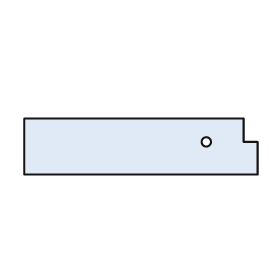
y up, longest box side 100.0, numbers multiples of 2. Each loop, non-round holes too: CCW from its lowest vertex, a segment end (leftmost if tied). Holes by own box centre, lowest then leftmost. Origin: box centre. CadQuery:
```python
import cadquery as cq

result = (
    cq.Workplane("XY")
    .moveTo(-50.0, -12.0)
    .lineTo(50.0, -12.0)
    .lineTo(50.0, 2.0)
    .lineTo(44.0, 2.0)
    .lineTo(44.0, 12.0)
    .lineTo(-50.0, 12.0)
    .close()
    .moveTo(28.0, 2.0)
    .circle(2.0)
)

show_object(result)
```